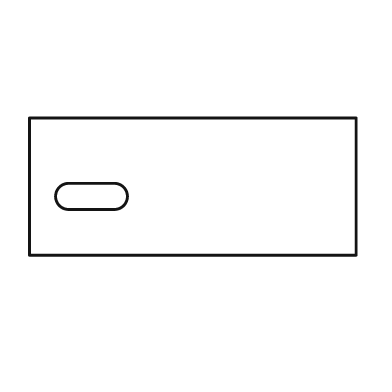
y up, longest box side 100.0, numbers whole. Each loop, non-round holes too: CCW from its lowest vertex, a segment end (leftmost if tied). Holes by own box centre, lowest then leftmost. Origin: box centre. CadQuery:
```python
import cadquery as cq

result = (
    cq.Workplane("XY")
    .moveTo(-50.0, -21.0)
    .lineTo(50.0, -21.0)
    .lineTo(50.0, 21.0)
    .lineTo(-50.0, 21.0)
    .close()
    .moveTo(-38.0, -7.0)
    .lineTo(-24.0, -7.0)
    .threePointArc((-20.0, -3.0), (-24.0, 1.0))
    .lineTo(-38.0, 1.0)
    .threePointArc((-42.0, -3.0), (-38.0, -7.0))
    .close()
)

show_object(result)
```